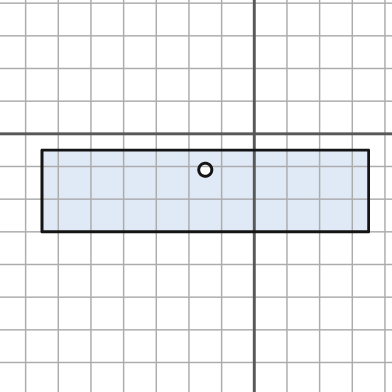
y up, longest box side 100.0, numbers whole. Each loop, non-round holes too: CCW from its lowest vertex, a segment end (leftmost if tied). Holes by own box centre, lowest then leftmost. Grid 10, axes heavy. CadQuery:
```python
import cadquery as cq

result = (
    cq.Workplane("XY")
    .moveTo(-65.0, -30.0)
    .lineTo(35.0, -30.0)
    .lineTo(35.0, -5.0)
    .lineTo(-65.0, -5.0)
    .close()
    .moveTo(-15.0, -11.0)
    .circle(2.0)
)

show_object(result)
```